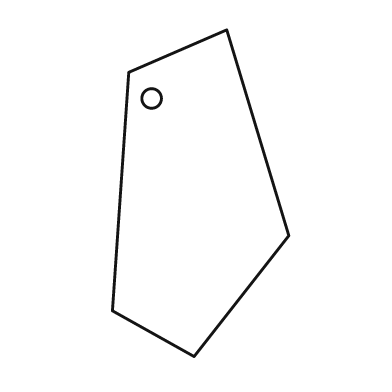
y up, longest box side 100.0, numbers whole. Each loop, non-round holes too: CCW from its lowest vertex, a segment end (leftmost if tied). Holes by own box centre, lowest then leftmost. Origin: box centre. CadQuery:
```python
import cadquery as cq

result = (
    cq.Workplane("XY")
    .moveTo(-2.0, -50.0)
    .lineTo(27.0, -13.0)
    .lineTo(8.0, 50.0)
    .lineTo(-22.0, 37.0)
    .lineTo(-27.0, -36.0)
    .close()
    .moveTo(-15.0, 29.0)
    .circle(3.0)
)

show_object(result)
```